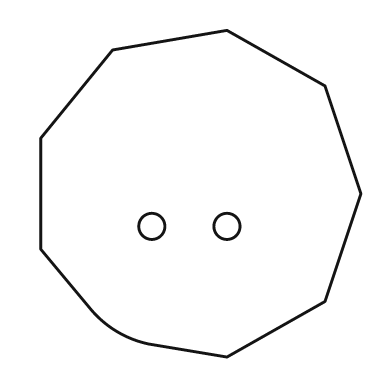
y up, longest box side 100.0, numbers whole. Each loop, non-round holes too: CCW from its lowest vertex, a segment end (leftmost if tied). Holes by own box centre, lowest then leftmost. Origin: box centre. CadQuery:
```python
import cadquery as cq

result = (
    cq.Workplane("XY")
    .moveTo(8.0, -50.0)
    .lineTo(38.0, -33.0)
    .lineTo(49.0, 0.0)
    .lineTo(38.0, 33.0)
    .lineTo(8.0, 50.0)
    .lineTo(-27.0, 44.0)
    .lineTo(-49.0, 17.0)
    .lineTo(-49.0, -17.0)
    .lineTo(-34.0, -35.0)
    .threePointArc((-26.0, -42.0), (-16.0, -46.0))
    .close()
    .moveTo(-15.0, -10.0)
    .circle(4.0)
    .moveTo(8.0, -10.0)
    .circle(4.0)
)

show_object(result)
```